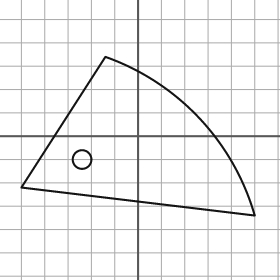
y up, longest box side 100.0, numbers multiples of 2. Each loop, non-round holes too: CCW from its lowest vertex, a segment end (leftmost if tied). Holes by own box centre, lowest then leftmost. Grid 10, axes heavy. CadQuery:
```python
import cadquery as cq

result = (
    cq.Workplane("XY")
    .moveTo(50.0, -34.0)
    .threePointArc((26.0, 8.0), (-14.0, 34.0))
    .lineTo(-50.0, -22.0)
    .close()
    .moveTo(-24.0, -10.0)
    .circle(4.0)
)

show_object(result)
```